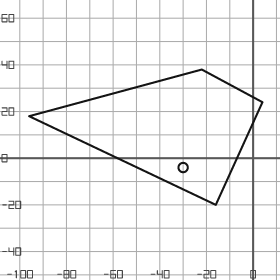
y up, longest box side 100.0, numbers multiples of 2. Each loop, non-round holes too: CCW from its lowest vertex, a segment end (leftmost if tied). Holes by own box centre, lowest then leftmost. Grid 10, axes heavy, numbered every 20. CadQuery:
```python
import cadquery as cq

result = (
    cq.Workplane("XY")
    .moveTo(-16.0, -20.0)
    .lineTo(4.0, 24.0)
    .lineTo(-22.0, 38.0)
    .lineTo(-96.0, 18.0)
    .close()
    .moveTo(-30.0, -4.0)
    .circle(2.0)
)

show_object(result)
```